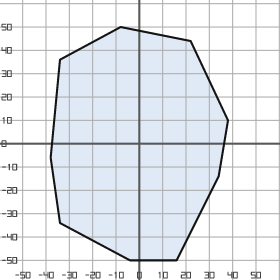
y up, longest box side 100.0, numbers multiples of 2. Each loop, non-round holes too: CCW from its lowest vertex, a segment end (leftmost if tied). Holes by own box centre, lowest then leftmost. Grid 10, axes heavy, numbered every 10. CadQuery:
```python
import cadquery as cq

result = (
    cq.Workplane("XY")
    .moveTo(-4.0, -50.0)
    .lineTo(16.0, -50.0)
    .lineTo(34.0, -14.0)
    .lineTo(38.0, 10.0)
    .lineTo(22.0, 44.0)
    .lineTo(-8.0, 50.0)
    .lineTo(-34.0, 36.0)
    .lineTo(-38.0, -6.0)
    .lineTo(-34.0, -34.0)
    .close()
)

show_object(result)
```